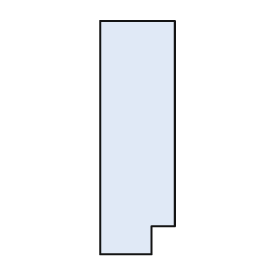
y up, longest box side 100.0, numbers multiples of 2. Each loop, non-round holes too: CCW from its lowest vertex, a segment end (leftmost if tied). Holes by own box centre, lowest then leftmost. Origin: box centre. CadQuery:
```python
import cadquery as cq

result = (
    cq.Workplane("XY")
    .moveTo(-16.0, -50.0)
    .lineTo(6.0, -50.0)
    .lineTo(6.0, -38.0)
    .lineTo(16.0, -38.0)
    .lineTo(16.0, 50.0)
    .lineTo(-16.0, 50.0)
    .close()
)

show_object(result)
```